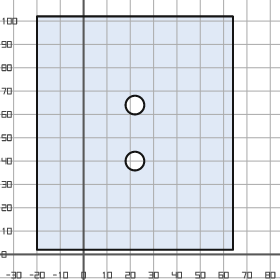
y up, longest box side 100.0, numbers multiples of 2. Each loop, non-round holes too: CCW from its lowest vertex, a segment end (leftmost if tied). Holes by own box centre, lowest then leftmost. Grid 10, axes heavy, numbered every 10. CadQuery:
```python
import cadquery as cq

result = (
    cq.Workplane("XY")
    .moveTo(-20.0, 2.0)
    .lineTo(64.0, 2.0)
    .lineTo(64.0, 102.0)
    .lineTo(-20.0, 102.0)
    .close()
    .moveTo(22.0, 40.0)
    .circle(4.0)
    .moveTo(22.0, 64.0)
    .circle(4.0)
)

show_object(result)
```